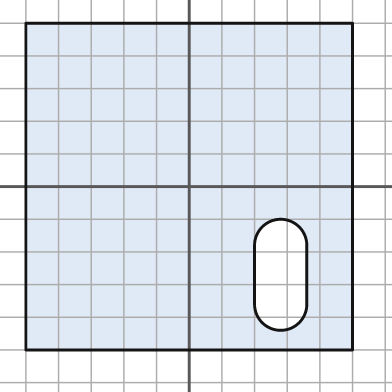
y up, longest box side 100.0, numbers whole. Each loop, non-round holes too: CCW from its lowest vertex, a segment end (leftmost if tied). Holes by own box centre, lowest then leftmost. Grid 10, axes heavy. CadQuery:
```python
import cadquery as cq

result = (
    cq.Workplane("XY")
    .moveTo(-50.0, -50.0)
    .lineTo(50.0, -50.0)
    .lineTo(50.0, 50.0)
    .lineTo(-50.0, 50.0)
    .close()
    .moveTo(20.0, -36.0)
    .threePointArc((28.0, -44.0), (36.0, -36.0))
    .lineTo(36.0, -18.0)
    .threePointArc((28.0, -10.0), (20.0, -18.0))
    .close()
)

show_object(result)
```